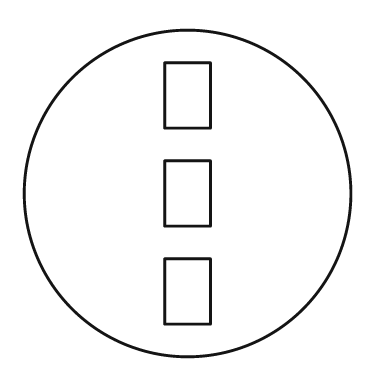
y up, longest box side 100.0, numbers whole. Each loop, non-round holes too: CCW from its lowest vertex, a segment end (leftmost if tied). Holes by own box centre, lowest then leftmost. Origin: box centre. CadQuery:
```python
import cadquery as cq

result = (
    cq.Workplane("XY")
    .moveTo(0.0, 0.0)
    .circle(50.0)
    .moveTo(-7.0, -40.0)
    .lineTo(7.0, -40.0)
    .lineTo(7.0, -20.0)
    .lineTo(-7.0, -20.0)
    .close()
    .moveTo(-7.0, -10.0)
    .lineTo(7.0, -10.0)
    .lineTo(7.0, 10.0)
    .lineTo(-7.0, 10.0)
    .close()
    .moveTo(-7.0, 20.0)
    .lineTo(7.0, 20.0)
    .lineTo(7.0, 40.0)
    .lineTo(-7.0, 40.0)
    .close()
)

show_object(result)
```